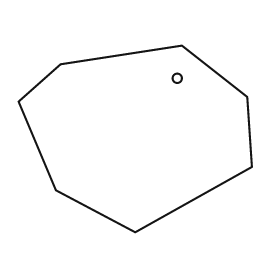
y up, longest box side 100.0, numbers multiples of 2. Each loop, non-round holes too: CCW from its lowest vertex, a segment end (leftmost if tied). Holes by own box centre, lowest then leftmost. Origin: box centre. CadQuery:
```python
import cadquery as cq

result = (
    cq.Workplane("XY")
    .moveTo(0.0, -40.0)
    .lineTo(50.0, -12.0)
    .lineTo(48.0, 18.0)
    .lineTo(20.0, 40.0)
    .lineTo(-32.0, 32.0)
    .lineTo(-50.0, 16.0)
    .lineTo(-34.0, -22.0)
    .close()
    .moveTo(18.0, 26.0)
    .circle(2.0)
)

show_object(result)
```